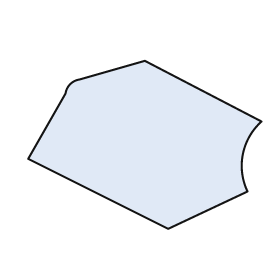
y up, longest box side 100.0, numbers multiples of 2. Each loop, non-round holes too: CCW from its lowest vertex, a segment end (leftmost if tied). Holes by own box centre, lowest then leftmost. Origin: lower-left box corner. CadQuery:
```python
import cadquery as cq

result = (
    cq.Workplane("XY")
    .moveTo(60.0, 0.0)
    .lineTo(94.0, 16.0)
    .threePointArc((92.0, 32.0), (100.0, 46.0))
    .lineTo(50.0, 72.0)
    .lineTo(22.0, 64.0)
    .threePointArc((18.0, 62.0), (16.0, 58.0))
    .lineTo(0.0, 30.0)
    .close()
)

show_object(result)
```